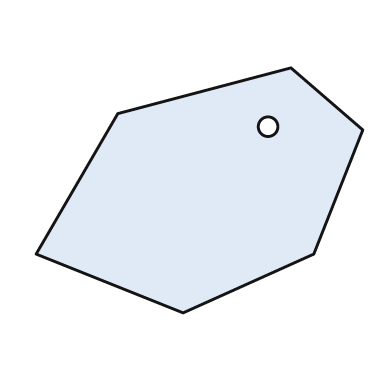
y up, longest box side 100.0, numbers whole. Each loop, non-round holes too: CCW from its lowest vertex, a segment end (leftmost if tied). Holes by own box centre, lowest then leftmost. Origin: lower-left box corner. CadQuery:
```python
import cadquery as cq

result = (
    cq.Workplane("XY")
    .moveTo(45.0, 0.0)
    .lineTo(85.0, 18.0)
    .lineTo(100.0, 56.0)
    .lineTo(78.0, 75.0)
    .lineTo(25.0, 61.0)
    .lineTo(0.0, 18.0)
    .close()
    .moveTo(71.0, 57.0)
    .circle(3.0)
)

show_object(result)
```